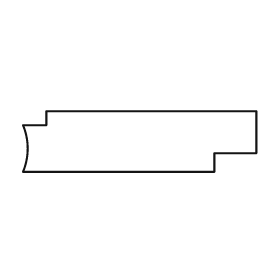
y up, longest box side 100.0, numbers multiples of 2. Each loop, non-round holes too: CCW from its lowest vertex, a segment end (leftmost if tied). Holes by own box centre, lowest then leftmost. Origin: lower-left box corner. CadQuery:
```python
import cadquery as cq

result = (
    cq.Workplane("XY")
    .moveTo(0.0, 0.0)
    .lineTo(82.0, 0.0)
    .lineTo(82.0, 8.0)
    .lineTo(100.0, 8.0)
    .lineTo(100.0, 26.0)
    .lineTo(10.0, 26.0)
    .lineTo(10.0, 20.0)
    .lineTo(0.0, 20.0)
    .threePointArc((2.0, 10.0), (0.0, 0.0))
    .close()
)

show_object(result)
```